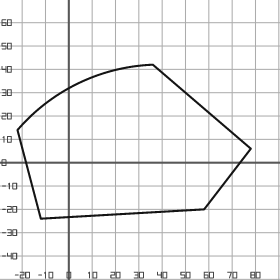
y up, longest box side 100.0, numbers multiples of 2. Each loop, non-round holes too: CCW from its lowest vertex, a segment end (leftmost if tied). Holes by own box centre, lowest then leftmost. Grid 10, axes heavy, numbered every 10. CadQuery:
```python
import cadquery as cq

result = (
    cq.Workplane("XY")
    .moveTo(-12.0, -24.0)
    .lineTo(58.0, -20.0)
    .lineTo(78.0, 6.0)
    .lineTo(36.0, 42.0)
    .threePointArc((4.0, 34.0), (-22.0, 14.0))
    .close()
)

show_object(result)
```